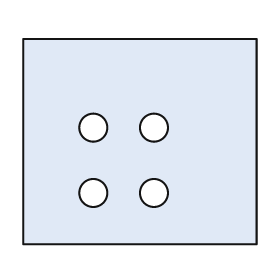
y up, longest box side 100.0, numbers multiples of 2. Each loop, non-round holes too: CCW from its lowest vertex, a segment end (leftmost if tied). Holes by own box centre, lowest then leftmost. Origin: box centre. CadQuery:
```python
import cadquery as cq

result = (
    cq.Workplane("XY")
    .moveTo(-50.0, -44.0)
    .lineTo(50.0, -44.0)
    .lineTo(50.0, 44.0)
    .lineTo(-50.0, 44.0)
    .close()
    .moveTo(-20.0, -22.0)
    .circle(6.0)
    .moveTo(6.0, -22.0)
    .circle(6.0)
    .moveTo(-20.0, 6.0)
    .circle(6.0)
    .moveTo(6.0, 6.0)
    .circle(6.0)
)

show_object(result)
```